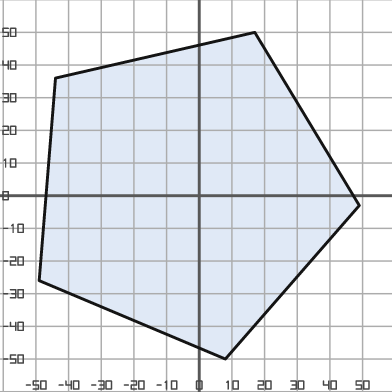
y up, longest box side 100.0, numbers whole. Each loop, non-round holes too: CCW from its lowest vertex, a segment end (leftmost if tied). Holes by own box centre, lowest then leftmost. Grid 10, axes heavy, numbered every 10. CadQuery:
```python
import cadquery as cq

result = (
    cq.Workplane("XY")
    .moveTo(8.0, -50.0)
    .lineTo(49.0, -3.0)
    .lineTo(17.0, 50.0)
    .lineTo(-44.0, 36.0)
    .lineTo(-49.0, -26.0)
    .close()
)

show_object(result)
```